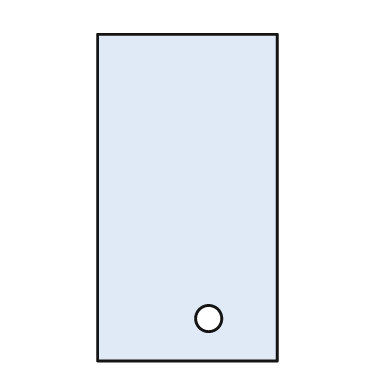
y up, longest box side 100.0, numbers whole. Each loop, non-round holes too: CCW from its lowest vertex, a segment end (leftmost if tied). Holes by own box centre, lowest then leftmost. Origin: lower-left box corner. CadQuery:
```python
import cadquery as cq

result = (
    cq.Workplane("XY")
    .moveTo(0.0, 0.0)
    .lineTo(55.0, 0.0)
    .lineTo(55.0, 100.0)
    .lineTo(0.0, 100.0)
    .close()
    .moveTo(34.0, 13.0)
    .circle(4.0)
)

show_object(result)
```